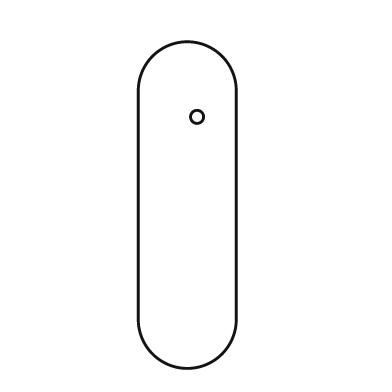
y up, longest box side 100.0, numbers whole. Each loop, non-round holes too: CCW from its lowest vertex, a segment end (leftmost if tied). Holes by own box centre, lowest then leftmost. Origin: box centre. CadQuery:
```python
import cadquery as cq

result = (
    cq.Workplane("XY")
    .moveTo(-15.0, -35.0)
    .threePointArc((0.0, -50.0), (15.0, -35.0))
    .lineTo(15.0, 35.0)
    .threePointArc((0.0, 50.0), (-15.0, 35.0))
    .close()
    .moveTo(3.0, 27.0)
    .circle(2.0)
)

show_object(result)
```